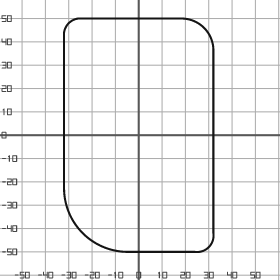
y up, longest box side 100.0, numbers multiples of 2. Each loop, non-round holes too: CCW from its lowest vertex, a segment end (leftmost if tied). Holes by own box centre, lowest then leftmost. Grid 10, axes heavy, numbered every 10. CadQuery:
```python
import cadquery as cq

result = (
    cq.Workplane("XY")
    .moveTo(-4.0, -50.0)
    .lineTo(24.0, -50.0)
    .threePointArc((30.0, -48.0), (32.0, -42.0))
    .lineTo(32.0, 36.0)
    .threePointArc((28.0, 46.0), (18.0, 50.0))
    .lineTo(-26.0, 50.0)
    .threePointArc((-30.0, 48.0), (-32.0, 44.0))
    .lineTo(-32.0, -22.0)
    .threePointArc((-24.0, -42.0), (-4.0, -50.0))
    .close()
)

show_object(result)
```